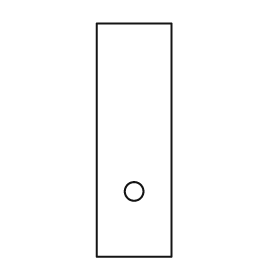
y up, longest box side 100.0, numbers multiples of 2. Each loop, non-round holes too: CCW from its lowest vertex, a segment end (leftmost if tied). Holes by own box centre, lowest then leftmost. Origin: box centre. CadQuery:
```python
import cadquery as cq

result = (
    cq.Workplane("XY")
    .moveTo(-16.0, -50.0)
    .lineTo(16.0, -50.0)
    .lineTo(16.0, 50.0)
    .lineTo(-16.0, 50.0)
    .close()
    .moveTo(0.0, -22.0)
    .circle(4.0)
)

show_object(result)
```